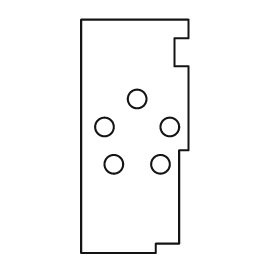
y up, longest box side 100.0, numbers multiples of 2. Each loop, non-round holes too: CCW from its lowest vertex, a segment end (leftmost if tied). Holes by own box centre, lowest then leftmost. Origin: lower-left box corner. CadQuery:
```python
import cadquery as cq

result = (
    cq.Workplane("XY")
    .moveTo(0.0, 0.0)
    .lineTo(32.0, 0.0)
    .lineTo(32.0, 4.0)
    .lineTo(42.0, 4.0)
    .lineTo(42.0, 44.0)
    .lineTo(46.0, 44.0)
    .lineTo(46.0, 80.0)
    .lineTo(40.0, 80.0)
    .lineTo(40.0, 92.0)
    .lineTo(46.0, 92.0)
    .lineTo(46.0, 100.0)
    .lineTo(0.0, 100.0)
    .close()
    .moveTo(14.0, 38.0)
    .circle(4.0)
    .moveTo(34.0, 38.0)
    .circle(4.0)
    .moveTo(10.0, 54.0)
    .circle(4.0)
    .moveTo(38.0, 54.0)
    .circle(4.0)
    .moveTo(24.0, 66.0)
    .circle(4.0)
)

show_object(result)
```